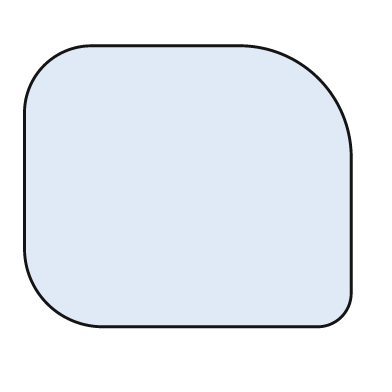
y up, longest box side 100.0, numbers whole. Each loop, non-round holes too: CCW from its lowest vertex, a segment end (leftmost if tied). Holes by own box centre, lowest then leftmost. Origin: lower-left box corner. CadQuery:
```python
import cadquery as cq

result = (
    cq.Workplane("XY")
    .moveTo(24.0, 0.0)
    .lineTo(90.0, 0.0)
    .threePointArc((97.0, 3.0), (100.0, 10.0))
    .lineTo(100.0, 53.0)
    .threePointArc((90.0, 76.0), (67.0, 86.0))
    .lineTo(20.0, 86.0)
    .threePointArc((6.0, 80.0), (0.0, 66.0))
    .lineTo(0.0, 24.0)
    .threePointArc((7.0, 7.0), (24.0, 0.0))
    .close()
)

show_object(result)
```